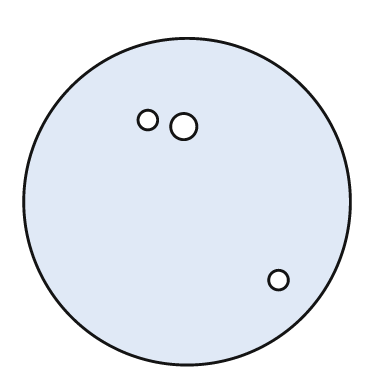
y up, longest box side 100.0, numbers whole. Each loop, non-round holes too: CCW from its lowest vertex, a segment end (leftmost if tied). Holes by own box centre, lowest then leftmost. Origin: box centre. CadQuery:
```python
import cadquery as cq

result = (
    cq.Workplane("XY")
    .moveTo(0.0, 0.0)
    .circle(50.0)
    .moveTo(28.0, -24.0)
    .circle(3.0)
    .moveTo(-1.0, 23.0)
    .circle(4.0)
    .moveTo(-12.0, 25.0)
    .circle(3.0)
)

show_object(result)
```